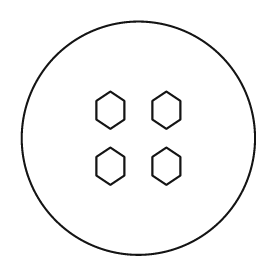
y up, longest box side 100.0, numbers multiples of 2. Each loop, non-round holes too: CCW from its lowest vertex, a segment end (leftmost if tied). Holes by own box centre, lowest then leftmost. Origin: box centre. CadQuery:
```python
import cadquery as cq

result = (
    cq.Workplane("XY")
    .moveTo(0.0, 0.0)
    .circle(50.0)
    .moveTo(-12.0, -20.0)
    .lineTo(-6.0, -16.0)
    .lineTo(-6.0, -8.0)
    .lineTo(-12.0, -4.0)
    .lineTo(-18.0, -8.0)
    .lineTo(-18.0, -16.0)
    .close()
    .moveTo(12.0, -20.0)
    .lineTo(18.0, -16.0)
    .lineTo(18.0, -8.0)
    .lineTo(12.0, -4.0)
    .lineTo(6.0, -8.0)
    .lineTo(6.0, -16.0)
    .close()
    .moveTo(-12.0, 4.0)
    .lineTo(-6.0, 8.0)
    .lineTo(-6.0, 16.0)
    .lineTo(-12.0, 20.0)
    .lineTo(-18.0, 16.0)
    .lineTo(-18.0, 8.0)
    .close()
    .moveTo(12.0, 4.0)
    .lineTo(18.0, 8.0)
    .lineTo(18.0, 16.0)
    .lineTo(12.0, 20.0)
    .lineTo(6.0, 16.0)
    .lineTo(6.0, 8.0)
    .close()
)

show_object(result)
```